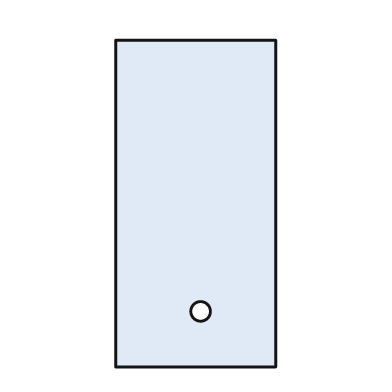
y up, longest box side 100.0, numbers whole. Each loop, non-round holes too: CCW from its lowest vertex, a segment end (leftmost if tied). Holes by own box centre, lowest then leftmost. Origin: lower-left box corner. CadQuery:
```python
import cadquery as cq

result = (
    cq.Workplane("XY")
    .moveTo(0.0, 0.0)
    .lineTo(49.0, 0.0)
    .lineTo(49.0, 100.0)
    .lineTo(0.0, 100.0)
    .close()
    .moveTo(26.0, 17.0)
    .circle(3.0)
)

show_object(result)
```